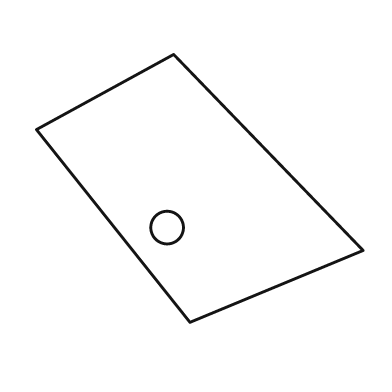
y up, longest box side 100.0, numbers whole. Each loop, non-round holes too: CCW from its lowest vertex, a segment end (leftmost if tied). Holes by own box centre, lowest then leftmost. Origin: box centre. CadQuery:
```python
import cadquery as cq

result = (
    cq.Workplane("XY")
    .moveTo(-3.0, -41.0)
    .lineTo(50.0, -19.0)
    .lineTo(-8.0, 41.0)
    .lineTo(-50.0, 18.0)
    .close()
    .moveTo(-10.0, -12.0)
    .circle(5.0)
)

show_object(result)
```